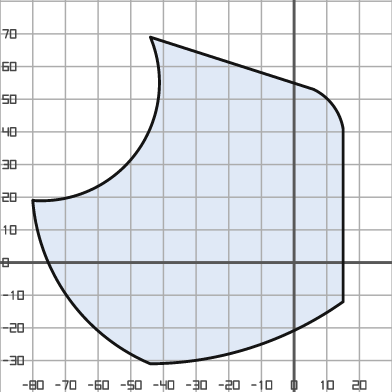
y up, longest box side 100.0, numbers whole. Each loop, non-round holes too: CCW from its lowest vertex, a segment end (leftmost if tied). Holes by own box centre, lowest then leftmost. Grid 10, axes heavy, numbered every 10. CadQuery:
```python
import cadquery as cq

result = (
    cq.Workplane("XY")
    .moveTo(-44.0, -31.0)
    .threePointArc((-13.0, -26.0), (15.0, -12.0))
    .lineTo(15.0, 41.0)
    .threePointArc((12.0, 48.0), (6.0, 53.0))
    .lineTo(-44.0, 69.0)
    .threePointArc((-48.0, 34.0), (-80.0, 19.0))
    .threePointArc((-69.0, -11.0), (-44.0, -31.0))
    .close()
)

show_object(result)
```